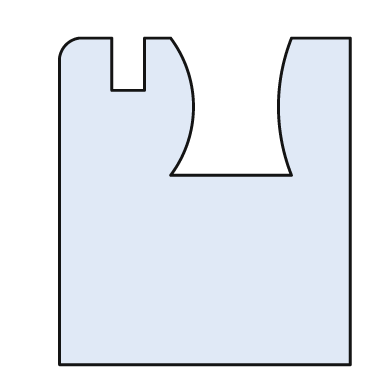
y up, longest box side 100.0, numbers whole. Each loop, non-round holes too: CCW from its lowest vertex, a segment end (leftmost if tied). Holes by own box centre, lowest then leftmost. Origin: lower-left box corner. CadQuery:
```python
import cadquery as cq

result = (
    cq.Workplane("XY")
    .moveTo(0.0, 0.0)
    .lineTo(89.0, 0.0)
    .lineTo(89.0, 100.0)
    .lineTo(71.0, 100.0)
    .threePointArc((67.0, 79.0), (71.0, 58.0))
    .lineTo(34.0, 58.0)
    .threePointArc((41.0, 79.0), (34.0, 100.0))
    .lineTo(26.0, 100.0)
    .lineTo(26.0, 84.0)
    .lineTo(16.0, 84.0)
    .lineTo(16.0, 100.0)
    .lineTo(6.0, 100.0)
    .threePointArc((2.0, 98.0), (0.0, 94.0))
    .close()
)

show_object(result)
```